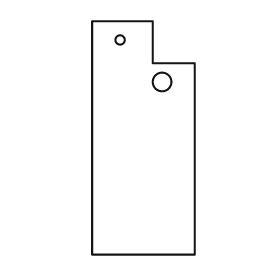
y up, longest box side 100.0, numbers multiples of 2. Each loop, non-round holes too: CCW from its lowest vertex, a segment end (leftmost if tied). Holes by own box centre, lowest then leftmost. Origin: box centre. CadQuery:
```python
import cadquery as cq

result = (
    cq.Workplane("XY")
    .moveTo(-22.0, -50.0)
    .lineTo(22.0, -50.0)
    .lineTo(22.0, 32.0)
    .lineTo(4.0, 32.0)
    .lineTo(4.0, 50.0)
    .lineTo(-22.0, 50.0)
    .close()
    .moveTo(8.0, 24.0)
    .circle(4.0)
    .moveTo(-10.0, 42.0)
    .circle(2.0)
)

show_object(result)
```